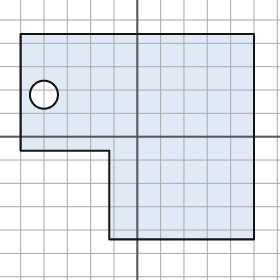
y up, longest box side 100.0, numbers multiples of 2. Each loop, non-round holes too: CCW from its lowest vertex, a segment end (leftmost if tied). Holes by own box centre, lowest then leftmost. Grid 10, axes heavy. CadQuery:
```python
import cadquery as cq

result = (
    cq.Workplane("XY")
    .moveTo(-12.0, -44.0)
    .lineTo(50.0, -44.0)
    .lineTo(50.0, 44.0)
    .lineTo(-50.0, 44.0)
    .lineTo(-50.0, -6.0)
    .lineTo(-12.0, -6.0)
    .close()
    .moveTo(-40.0, 18.0)
    .circle(6.0)
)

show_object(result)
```